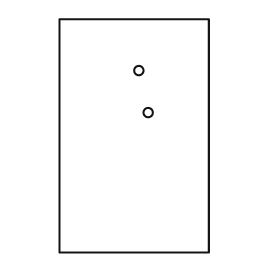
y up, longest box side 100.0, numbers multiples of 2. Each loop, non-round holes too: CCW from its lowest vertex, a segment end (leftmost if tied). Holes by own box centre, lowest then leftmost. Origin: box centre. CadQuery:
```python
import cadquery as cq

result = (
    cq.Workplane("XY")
    .moveTo(-32.0, -50.0)
    .lineTo(32.0, -50.0)
    .lineTo(32.0, 50.0)
    .lineTo(-32.0, 50.0)
    .close()
    .moveTo(6.0, 10.0)
    .circle(2.0)
    .moveTo(2.0, 28.0)
    .circle(2.0)
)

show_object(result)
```